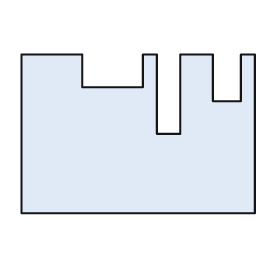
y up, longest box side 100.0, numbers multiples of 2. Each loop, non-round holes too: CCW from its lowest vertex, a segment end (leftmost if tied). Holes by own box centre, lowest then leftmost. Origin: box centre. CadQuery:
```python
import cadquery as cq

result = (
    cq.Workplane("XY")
    .moveTo(-50.0, -34.0)
    .lineTo(50.0, -34.0)
    .lineTo(50.0, 34.0)
    .lineTo(44.0, 34.0)
    .lineTo(44.0, 14.0)
    .lineTo(32.0, 14.0)
    .lineTo(32.0, 34.0)
    .lineTo(18.0, 34.0)
    .lineTo(18.0, 0.0)
    .lineTo(8.0, 0.0)
    .lineTo(8.0, 34.0)
    .lineTo(2.0, 34.0)
    .lineTo(2.0, 20.0)
    .lineTo(-24.0, 20.0)
    .lineTo(-24.0, 34.0)
    .lineTo(-50.0, 34.0)
    .close()
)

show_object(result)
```